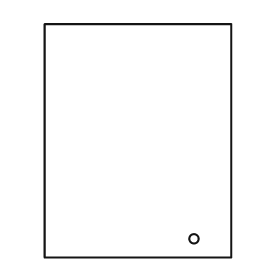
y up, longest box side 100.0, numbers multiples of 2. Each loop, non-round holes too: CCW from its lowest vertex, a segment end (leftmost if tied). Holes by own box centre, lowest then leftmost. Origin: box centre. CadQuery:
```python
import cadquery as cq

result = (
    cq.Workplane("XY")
    .moveTo(-40.0, -50.0)
    .lineTo(40.0, -50.0)
    .lineTo(40.0, 50.0)
    .lineTo(-40.0, 50.0)
    .close()
    .moveTo(24.0, -42.0)
    .circle(2.0)
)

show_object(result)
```